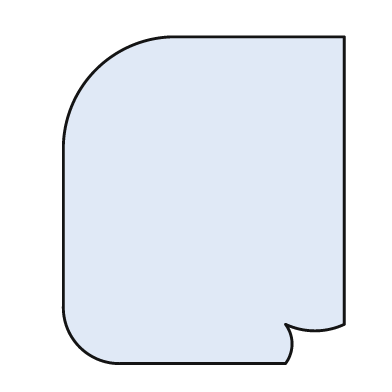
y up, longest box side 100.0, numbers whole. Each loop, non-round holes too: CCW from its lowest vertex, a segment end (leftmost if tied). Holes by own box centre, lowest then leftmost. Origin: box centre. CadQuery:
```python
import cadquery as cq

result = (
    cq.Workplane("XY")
    .moveTo(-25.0, -50.0)
    .lineTo(25.0, -50.0)
    .threePointArc((27.0, -44.0), (25.0, -38.0))
    .threePointArc((34.0, -40.0), (43.0, -38.0))
    .lineTo(43.0, 50.0)
    .lineTo(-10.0, 50.0)
    .threePointArc((-33.0, 40.0), (-43.0, 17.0))
    .lineTo(-43.0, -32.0)
    .threePointArc((-38.0, -45.0), (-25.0, -50.0))
    .close()
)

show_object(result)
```